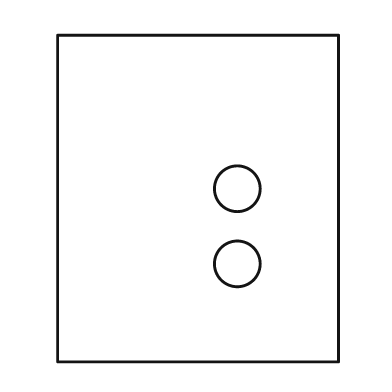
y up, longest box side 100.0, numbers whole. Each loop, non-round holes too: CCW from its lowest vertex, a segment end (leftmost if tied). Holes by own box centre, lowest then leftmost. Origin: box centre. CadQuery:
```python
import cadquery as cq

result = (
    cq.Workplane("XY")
    .moveTo(-43.0, -50.0)
    .lineTo(43.0, -50.0)
    .lineTo(43.0, 50.0)
    .lineTo(-43.0, 50.0)
    .close()
    .moveTo(12.0, -20.0)
    .circle(7.0)
    .moveTo(12.0, 3.0)
    .circle(7.0)
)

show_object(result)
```